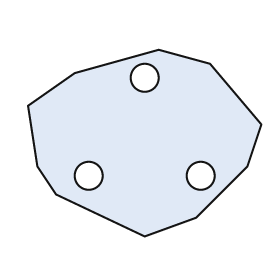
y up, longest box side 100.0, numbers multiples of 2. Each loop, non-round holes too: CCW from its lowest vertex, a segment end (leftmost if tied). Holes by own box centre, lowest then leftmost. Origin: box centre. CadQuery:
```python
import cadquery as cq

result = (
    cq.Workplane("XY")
    .moveTo(0.0, -40.0)
    .lineTo(22.0, -32.0)
    .lineTo(44.0, -10.0)
    .lineTo(50.0, 8.0)
    .lineTo(28.0, 34.0)
    .lineTo(6.0, 40.0)
    .lineTo(-30.0, 30.0)
    .lineTo(-50.0, 16.0)
    .lineTo(-46.0, -10.0)
    .lineTo(-38.0, -22.0)
    .close()
    .moveTo(-24.0, -14.0)
    .circle(6.0)
    .moveTo(24.0, -14.0)
    .circle(6.0)
    .moveTo(0.0, 28.0)
    .circle(6.0)
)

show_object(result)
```